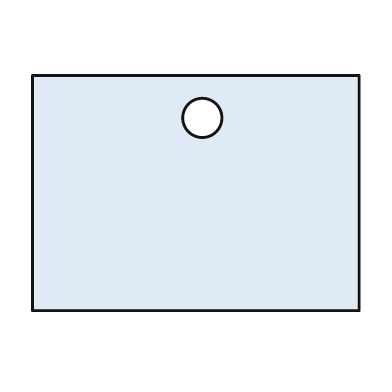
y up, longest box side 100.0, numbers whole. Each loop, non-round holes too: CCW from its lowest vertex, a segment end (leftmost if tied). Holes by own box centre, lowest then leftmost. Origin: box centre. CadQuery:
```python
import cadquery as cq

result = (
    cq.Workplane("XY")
    .moveTo(-50.0, -36.0)
    .lineTo(50.0, -36.0)
    .lineTo(50.0, 36.0)
    .lineTo(-50.0, 36.0)
    .close()
    .moveTo(2.0, 23.0)
    .circle(6.0)
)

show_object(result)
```